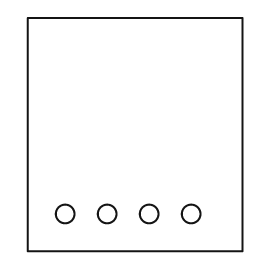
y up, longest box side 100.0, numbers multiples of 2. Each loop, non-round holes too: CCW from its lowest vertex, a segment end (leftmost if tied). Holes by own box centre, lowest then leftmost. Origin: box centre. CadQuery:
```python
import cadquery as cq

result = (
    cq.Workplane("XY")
    .moveTo(-46.0, -50.0)
    .lineTo(46.0, -50.0)
    .lineTo(46.0, 50.0)
    .lineTo(-46.0, 50.0)
    .close()
    .moveTo(-30.0, -34.0)
    .circle(4.0)
    .moveTo(-12.0, -34.0)
    .circle(4.0)
    .moveTo(6.0, -34.0)
    .circle(4.0)
    .moveTo(24.0, -34.0)
    .circle(4.0)
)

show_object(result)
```